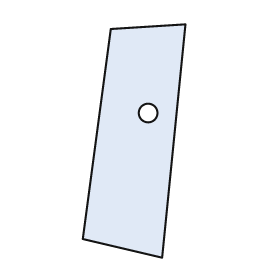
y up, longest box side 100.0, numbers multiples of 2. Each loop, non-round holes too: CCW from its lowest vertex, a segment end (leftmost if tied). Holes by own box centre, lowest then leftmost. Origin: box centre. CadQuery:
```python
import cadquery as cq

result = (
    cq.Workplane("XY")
    .moveTo(12.0, -50.0)
    .lineTo(22.0, 50.0)
    .lineTo(-10.0, 48.0)
    .lineTo(-22.0, -42.0)
    .close()
    .moveTo(6.0, 12.0)
    .circle(4.0)
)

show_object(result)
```